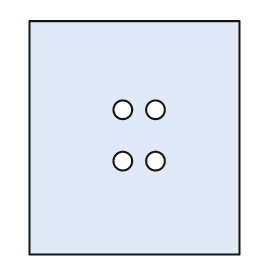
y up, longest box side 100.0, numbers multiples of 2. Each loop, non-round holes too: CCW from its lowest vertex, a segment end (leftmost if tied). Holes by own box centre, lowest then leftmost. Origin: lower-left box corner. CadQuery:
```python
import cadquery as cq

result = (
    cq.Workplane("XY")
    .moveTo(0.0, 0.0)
    .lineTo(90.0, 0.0)
    .lineTo(90.0, 100.0)
    .lineTo(0.0, 100.0)
    .close()
    .moveTo(40.0, 40.0)
    .circle(4.0)
    .moveTo(54.0, 40.0)
    .circle(4.0)
    .moveTo(40.0, 62.0)
    .circle(4.0)
    .moveTo(54.0, 62.0)
    .circle(4.0)
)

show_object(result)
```